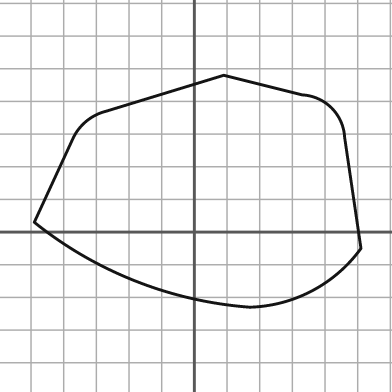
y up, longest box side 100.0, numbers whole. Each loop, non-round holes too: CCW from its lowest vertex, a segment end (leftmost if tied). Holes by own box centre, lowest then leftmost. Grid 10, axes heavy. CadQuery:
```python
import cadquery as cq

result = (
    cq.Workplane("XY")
    .moveTo(17.0, -23.0)
    .threePointArc((36.0, -18.0), (51.0, -5.0))
    .lineTo(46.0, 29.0)
    .threePointArc((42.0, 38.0), (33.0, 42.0))
    .lineTo(9.0, 48.0)
    .lineTo(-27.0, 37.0)
    .threePointArc((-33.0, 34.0), (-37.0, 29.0))
    .lineTo(-49.0, 3.0)
    .threePointArc((-18.0, -15.0), (17.0, -23.0))
    .close()
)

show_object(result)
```